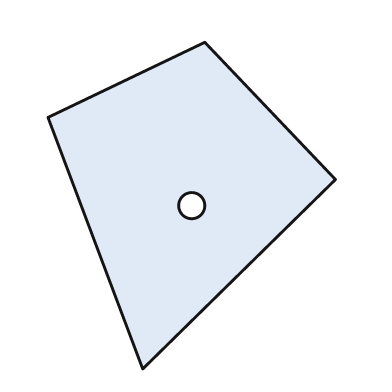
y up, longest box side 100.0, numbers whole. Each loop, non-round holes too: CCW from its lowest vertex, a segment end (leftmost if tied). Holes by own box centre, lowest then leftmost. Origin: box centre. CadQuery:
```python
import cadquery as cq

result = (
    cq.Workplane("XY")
    .moveTo(-15.0, -50.0)
    .lineTo(44.0, 8.0)
    .lineTo(4.0, 50.0)
    .lineTo(-44.0, 27.0)
    .close()
    .moveTo(0.0, 0.0)
    .circle(4.0)
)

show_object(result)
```